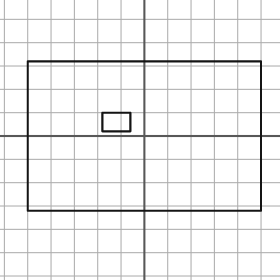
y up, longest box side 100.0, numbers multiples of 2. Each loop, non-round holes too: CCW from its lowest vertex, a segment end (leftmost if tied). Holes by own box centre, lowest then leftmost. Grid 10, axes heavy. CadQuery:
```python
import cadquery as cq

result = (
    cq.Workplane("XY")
    .moveTo(-50.0, -32.0)
    .lineTo(50.0, -32.0)
    .lineTo(50.0, 32.0)
    .lineTo(-50.0, 32.0)
    .close()
    .moveTo(-18.0, 2.0)
    .lineTo(-6.0, 2.0)
    .lineTo(-6.0, 10.0)
    .lineTo(-18.0, 10.0)
    .close()
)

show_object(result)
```